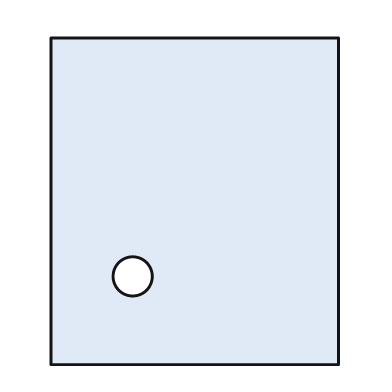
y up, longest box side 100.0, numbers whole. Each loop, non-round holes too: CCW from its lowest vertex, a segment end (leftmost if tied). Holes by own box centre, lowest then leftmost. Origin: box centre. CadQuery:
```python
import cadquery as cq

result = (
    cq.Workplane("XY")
    .moveTo(-44.0, -50.0)
    .lineTo(44.0, -50.0)
    .lineTo(44.0, 50.0)
    .lineTo(-44.0, 50.0)
    .close()
    .moveTo(-19.0, -23.0)
    .circle(6.0)
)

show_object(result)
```